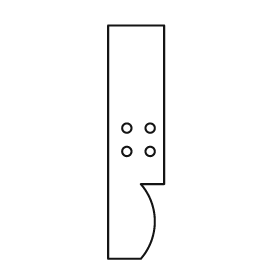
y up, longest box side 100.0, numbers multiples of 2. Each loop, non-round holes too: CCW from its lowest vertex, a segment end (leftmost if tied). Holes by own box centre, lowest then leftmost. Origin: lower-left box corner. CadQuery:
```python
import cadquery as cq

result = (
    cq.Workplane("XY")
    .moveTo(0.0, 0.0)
    .lineTo(14.0, 0.0)
    .threePointArc((20.0, 16.0), (14.0, 32.0))
    .lineTo(24.0, 32.0)
    .lineTo(24.0, 100.0)
    .lineTo(0.0, 100.0)
    .close()
    .moveTo(8.0, 46.0)
    .circle(2.0)
    .moveTo(18.0, 46.0)
    .circle(2.0)
    .moveTo(8.0, 56.0)
    .circle(2.0)
    .moveTo(18.0, 56.0)
    .circle(2.0)
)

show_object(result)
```